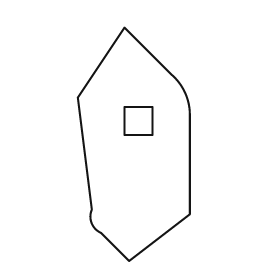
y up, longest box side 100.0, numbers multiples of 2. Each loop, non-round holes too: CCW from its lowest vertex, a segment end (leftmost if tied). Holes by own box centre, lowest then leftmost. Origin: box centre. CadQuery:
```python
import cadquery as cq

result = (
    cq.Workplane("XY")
    .moveTo(-2.0, -50.0)
    .lineTo(24.0, -30.0)
    .lineTo(24.0, 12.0)
    .threePointArc((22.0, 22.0), (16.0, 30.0))
    .lineTo(-4.0, 50.0)
    .lineTo(-24.0, 20.0)
    .lineTo(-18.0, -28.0)
    .threePointArc((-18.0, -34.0), (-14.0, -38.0))
    .close()
    .moveTo(-4.0, 4.0)
    .lineTo(8.0, 4.0)
    .lineTo(8.0, 16.0)
    .lineTo(-4.0, 16.0)
    .close()
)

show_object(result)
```